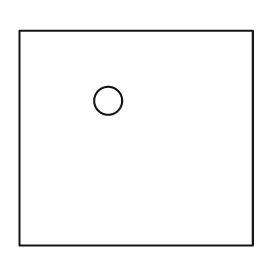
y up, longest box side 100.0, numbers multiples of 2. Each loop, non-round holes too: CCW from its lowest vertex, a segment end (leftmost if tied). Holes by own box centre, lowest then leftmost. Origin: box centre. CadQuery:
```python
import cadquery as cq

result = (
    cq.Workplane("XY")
    .moveTo(-50.0, -46.0)
    .lineTo(50.0, -46.0)
    .lineTo(50.0, 46.0)
    .lineTo(-50.0, 46.0)
    .close()
    .moveTo(-12.0, 16.0)
    .circle(6.0)
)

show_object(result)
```